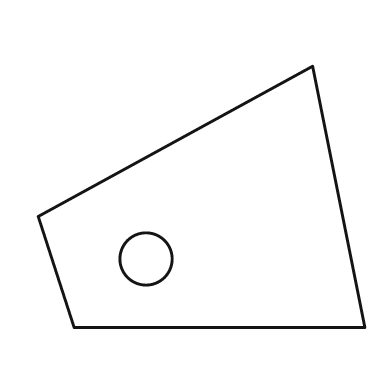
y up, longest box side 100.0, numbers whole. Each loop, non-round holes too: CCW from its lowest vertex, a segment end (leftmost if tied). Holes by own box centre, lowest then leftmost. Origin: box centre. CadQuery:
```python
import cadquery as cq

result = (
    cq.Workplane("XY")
    .moveTo(-39.0, -40.0)
    .lineTo(50.0, -40.0)
    .lineTo(34.0, 40.0)
    .lineTo(-50.0, -6.0)
    .close()
    .moveTo(-17.0, -19.0)
    .circle(8.0)
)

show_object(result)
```